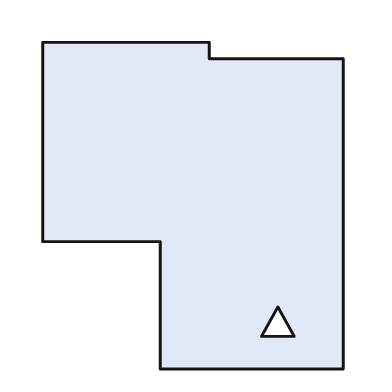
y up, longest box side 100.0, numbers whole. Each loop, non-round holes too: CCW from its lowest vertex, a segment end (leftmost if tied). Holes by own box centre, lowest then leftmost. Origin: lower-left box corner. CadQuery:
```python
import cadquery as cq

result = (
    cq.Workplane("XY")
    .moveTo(36.0, 0.0)
    .lineTo(92.0, 0.0)
    .lineTo(92.0, 95.0)
    .lineTo(51.0, 95.0)
    .lineTo(51.0, 100.0)
    .lineTo(0.0, 100.0)
    .lineTo(0.0, 39.0)
    .lineTo(36.0, 39.0)
    .close()
    .moveTo(67.0, 10.0)
    .lineTo(77.0, 10.0)
    .lineTo(72.0, 19.0)
    .close()
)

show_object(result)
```